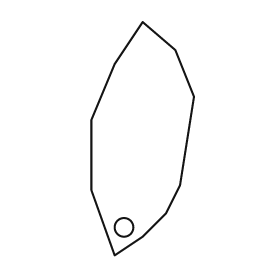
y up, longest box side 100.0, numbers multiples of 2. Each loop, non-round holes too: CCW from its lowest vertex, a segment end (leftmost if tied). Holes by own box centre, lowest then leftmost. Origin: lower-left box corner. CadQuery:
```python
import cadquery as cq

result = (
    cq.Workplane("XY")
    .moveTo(10.0, 0.0)
    .lineTo(22.0, 8.0)
    .lineTo(32.0, 18.0)
    .lineTo(38.0, 30.0)
    .lineTo(44.0, 68.0)
    .lineTo(36.0, 88.0)
    .lineTo(22.0, 100.0)
    .lineTo(10.0, 82.0)
    .lineTo(0.0, 58.0)
    .lineTo(0.0, 28.0)
    .close()
    .moveTo(14.0, 12.0)
    .circle(4.0)
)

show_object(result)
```